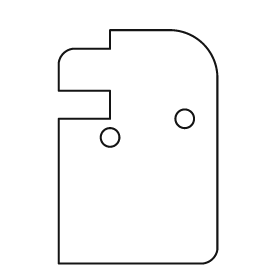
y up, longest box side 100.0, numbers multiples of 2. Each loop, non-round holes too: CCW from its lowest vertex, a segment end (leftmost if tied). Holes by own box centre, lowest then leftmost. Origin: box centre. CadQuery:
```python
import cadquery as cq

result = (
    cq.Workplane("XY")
    .moveTo(-34.0, -50.0)
    .lineTo(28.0, -50.0)
    .threePointArc((32.0, -48.0), (34.0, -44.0))
    .lineTo(34.0, 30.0)
    .threePointArc((28.0, 44.0), (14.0, 50.0))
    .lineTo(-12.0, 50.0)
    .lineTo(-12.0, 42.0)
    .lineTo(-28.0, 42.0)
    .threePointArc((-32.0, 40.0), (-34.0, 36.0))
    .lineTo(-34.0, 24.0)
    .lineTo(-12.0, 24.0)
    .lineTo(-12.0, 12.0)
    .lineTo(-34.0, 12.0)
    .close()
    .moveTo(-12.0, 4.0)
    .circle(4.0)
    .moveTo(20.0, 12.0)
    .circle(4.0)
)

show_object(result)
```